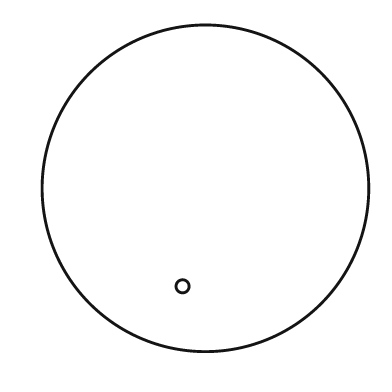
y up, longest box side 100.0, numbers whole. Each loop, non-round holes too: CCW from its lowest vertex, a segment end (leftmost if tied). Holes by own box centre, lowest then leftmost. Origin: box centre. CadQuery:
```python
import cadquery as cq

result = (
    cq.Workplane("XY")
    .moveTo(0.0, 0.0)
    .circle(50.0)
    .moveTo(-7.0, -30.0)
    .circle(2.0)
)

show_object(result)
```